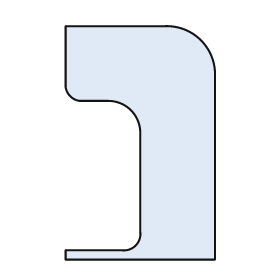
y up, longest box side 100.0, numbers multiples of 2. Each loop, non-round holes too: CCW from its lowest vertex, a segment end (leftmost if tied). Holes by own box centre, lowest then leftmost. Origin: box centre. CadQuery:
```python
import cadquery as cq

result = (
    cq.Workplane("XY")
    .moveTo(-32.0, -50.0)
    .lineTo(32.0, -50.0)
    .lineTo(32.0, 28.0)
    .threePointArc((26.0, 44.0), (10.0, 50.0))
    .lineTo(-32.0, 50.0)
    .lineTo(-32.0, 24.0)
    .threePointArc((-30.0, 20.0), (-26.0, 18.0))
    .lineTo(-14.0, 18.0)
    .threePointArc((-4.0, 14.0), (0.0, 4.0))
    .lineTo(0.0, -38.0)
    .threePointArc((-2.0, -44.0), (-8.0, -46.0))
    .lineTo(-32.0, -46.0)
    .close()
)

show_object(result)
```